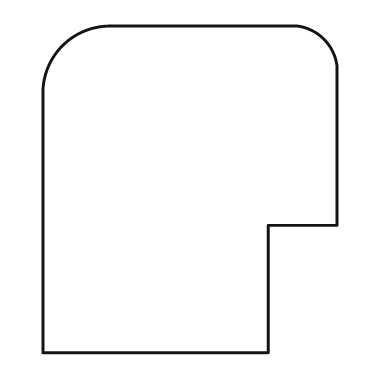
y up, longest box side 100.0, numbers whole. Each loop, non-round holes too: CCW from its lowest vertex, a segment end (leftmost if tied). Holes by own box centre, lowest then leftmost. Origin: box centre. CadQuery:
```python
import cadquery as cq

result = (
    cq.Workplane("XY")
    .moveTo(-45.0, -50.0)
    .lineTo(24.0, -50.0)
    .lineTo(24.0, -11.0)
    .lineTo(45.0, -11.0)
    .lineTo(45.0, 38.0)
    .threePointArc((41.0, 46.0), (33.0, 50.0))
    .lineTo(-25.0, 50.0)
    .threePointArc((-39.0, 44.0), (-45.0, 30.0))
    .close()
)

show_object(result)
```